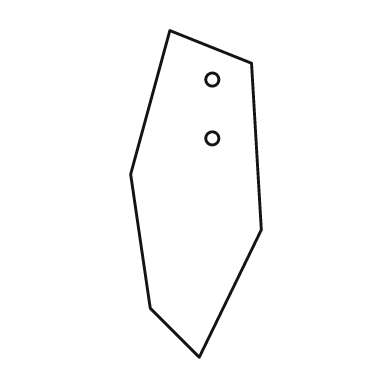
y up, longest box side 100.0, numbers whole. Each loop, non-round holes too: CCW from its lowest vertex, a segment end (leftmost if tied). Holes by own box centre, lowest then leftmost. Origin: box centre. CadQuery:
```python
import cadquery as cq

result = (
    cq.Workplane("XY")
    .moveTo(1.0, -50.0)
    .lineTo(20.0, -11.0)
    .lineTo(17.0, 40.0)
    .lineTo(-8.0, 50.0)
    .lineTo(-20.0, 6.0)
    .lineTo(-14.0, -35.0)
    .close()
    .moveTo(5.0, 17.0)
    .circle(2.0)
    .moveTo(5.0, 35.0)
    .circle(2.0)
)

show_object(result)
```